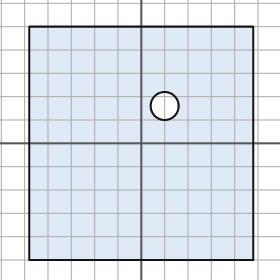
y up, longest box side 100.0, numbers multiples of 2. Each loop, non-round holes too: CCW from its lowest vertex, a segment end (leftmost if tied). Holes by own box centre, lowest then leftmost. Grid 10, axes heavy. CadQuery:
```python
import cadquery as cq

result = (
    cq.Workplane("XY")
    .moveTo(-48.0, -50.0)
    .lineTo(48.0, -50.0)
    .lineTo(48.0, 50.0)
    .lineTo(-48.0, 50.0)
    .close()
    .moveTo(10.0, 16.0)
    .circle(6.0)
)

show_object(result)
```